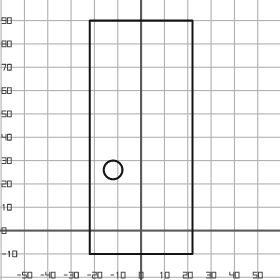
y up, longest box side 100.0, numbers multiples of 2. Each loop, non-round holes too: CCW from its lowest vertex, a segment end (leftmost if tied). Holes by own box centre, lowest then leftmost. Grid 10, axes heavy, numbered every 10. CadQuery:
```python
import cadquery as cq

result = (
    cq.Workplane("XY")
    .moveTo(-22.0, -10.0)
    .lineTo(22.0, -10.0)
    .lineTo(22.0, 90.0)
    .lineTo(-22.0, 90.0)
    .close()
    .moveTo(-12.0, 26.0)
    .circle(4.0)
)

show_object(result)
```